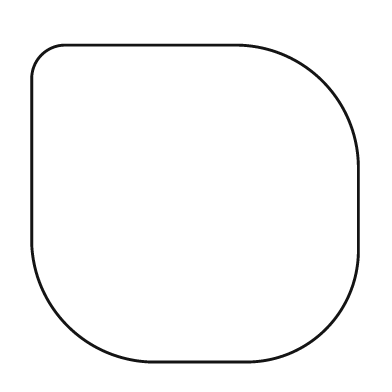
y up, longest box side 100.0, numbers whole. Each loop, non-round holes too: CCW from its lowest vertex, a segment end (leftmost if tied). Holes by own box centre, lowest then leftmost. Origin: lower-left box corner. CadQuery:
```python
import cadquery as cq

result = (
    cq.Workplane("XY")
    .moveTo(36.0, 0.0)
    .lineTo(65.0, 0.0)
    .threePointArc((90.0, 10.0), (100.0, 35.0))
    .lineTo(100.0, 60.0)
    .threePointArc((89.0, 86.0), (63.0, 97.0))
    .lineTo(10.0, 97.0)
    .threePointArc((3.0, 94.0), (0.0, 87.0))
    .lineTo(0.0, 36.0)
    .threePointArc((11.0, 11.0), (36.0, 0.0))
    .close()
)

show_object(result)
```